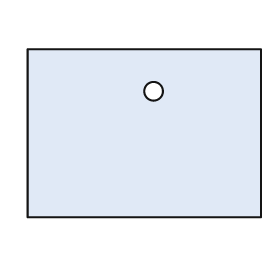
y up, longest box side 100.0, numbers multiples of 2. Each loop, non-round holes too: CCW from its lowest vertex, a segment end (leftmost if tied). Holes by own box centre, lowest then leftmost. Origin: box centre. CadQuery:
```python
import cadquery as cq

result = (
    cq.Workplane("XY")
    .moveTo(-50.0, -36.0)
    .lineTo(50.0, -36.0)
    .lineTo(50.0, 36.0)
    .lineTo(-50.0, 36.0)
    .close()
    .moveTo(4.0, 18.0)
    .circle(4.0)
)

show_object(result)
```